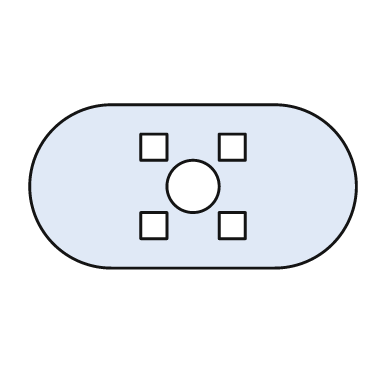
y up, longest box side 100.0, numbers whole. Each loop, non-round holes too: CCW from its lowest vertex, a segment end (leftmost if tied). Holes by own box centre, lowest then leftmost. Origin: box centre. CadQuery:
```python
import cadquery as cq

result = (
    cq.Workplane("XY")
    .moveTo(-25.0, -25.0)
    .lineTo(25.0, -25.0)
    .threePointArc((50.0, 0.0), (25.0, 25.0))
    .lineTo(-25.0, 25.0)
    .threePointArc((-50.0, 0.0), (-25.0, -25.0))
    .close()
    .moveTo(-16.0, -16.0)
    .lineTo(-8.0, -16.0)
    .lineTo(-8.0, -8.0)
    .lineTo(-16.0, -8.0)
    .close()
    .moveTo(8.0, -16.0)
    .lineTo(16.0, -16.0)
    .lineTo(16.0, -8.0)
    .lineTo(8.0, -8.0)
    .close()
    .moveTo(0.0, 0.0)
    .circle(8.0)
    .moveTo(-16.0, 8.0)
    .lineTo(-8.0, 8.0)
    .lineTo(-8.0, 16.0)
    .lineTo(-16.0, 16.0)
    .close()
    .moveTo(8.0, 8.0)
    .lineTo(16.0, 8.0)
    .lineTo(16.0, 16.0)
    .lineTo(8.0, 16.0)
    .close()
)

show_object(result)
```